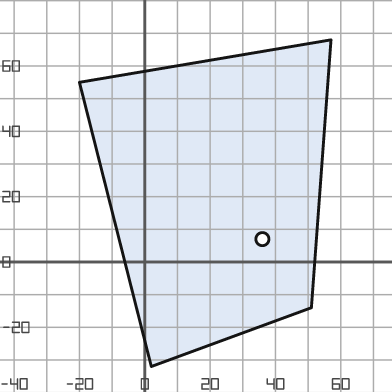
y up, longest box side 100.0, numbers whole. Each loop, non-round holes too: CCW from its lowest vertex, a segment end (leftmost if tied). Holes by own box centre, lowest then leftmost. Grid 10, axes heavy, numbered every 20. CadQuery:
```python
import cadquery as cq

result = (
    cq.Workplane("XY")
    .moveTo(2.0, -32.0)
    .lineTo(51.0, -14.0)
    .lineTo(57.0, 68.0)
    .lineTo(-20.0, 55.0)
    .close()
    .moveTo(36.0, 7.0)
    .circle(2.0)
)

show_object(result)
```